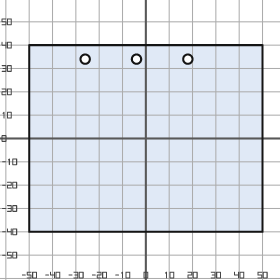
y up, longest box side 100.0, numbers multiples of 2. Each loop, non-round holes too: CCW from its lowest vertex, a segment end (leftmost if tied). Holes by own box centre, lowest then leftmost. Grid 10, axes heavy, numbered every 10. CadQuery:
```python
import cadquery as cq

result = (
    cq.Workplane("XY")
    .moveTo(-50.0, -40.0)
    .lineTo(50.0, -40.0)
    .lineTo(50.0, 40.0)
    .lineTo(-50.0, 40.0)
    .close()
    .moveTo(-26.0, 34.0)
    .circle(2.0)
    .moveTo(-4.0, 34.0)
    .circle(2.0)
    .moveTo(18.0, 34.0)
    .circle(2.0)
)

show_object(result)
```